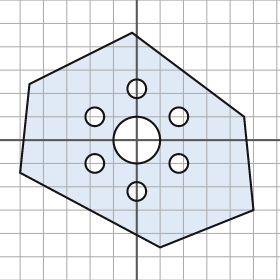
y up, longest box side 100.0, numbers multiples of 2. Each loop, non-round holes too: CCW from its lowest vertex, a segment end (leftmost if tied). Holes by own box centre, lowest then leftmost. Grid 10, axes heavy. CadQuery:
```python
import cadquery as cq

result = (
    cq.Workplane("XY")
    .moveTo(10.0, -46.0)
    .lineTo(50.0, -30.0)
    .lineTo(46.0, 10.0)
    .lineTo(-2.0, 46.0)
    .lineTo(-46.0, 24.0)
    .lineTo(-50.0, -14.0)
    .close()
    .moveTo(0.0, -22.0)
    .circle(4.0)
    .moveTo(-18.0, -10.0)
    .circle(4.0)
    .moveTo(18.0, -10.0)
    .circle(4.0)
    .moveTo(0.0, 0.0)
    .circle(10.0)
    .moveTo(-18.0, 10.0)
    .circle(4.0)
    .moveTo(18.0, 10.0)
    .circle(4.0)
    .moveTo(0.0, 22.0)
    .circle(4.0)
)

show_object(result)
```